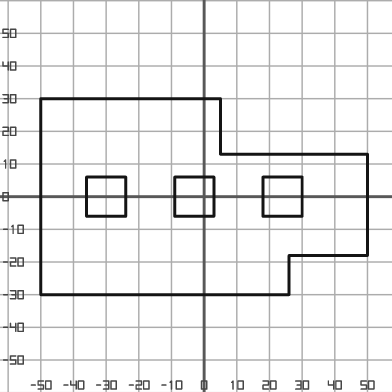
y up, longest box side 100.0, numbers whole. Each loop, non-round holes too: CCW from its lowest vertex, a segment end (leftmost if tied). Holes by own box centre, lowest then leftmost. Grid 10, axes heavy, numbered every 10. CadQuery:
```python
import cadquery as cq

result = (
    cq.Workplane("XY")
    .moveTo(-50.0, -30.0)
    .lineTo(26.0, -30.0)
    .lineTo(26.0, -18.0)
    .lineTo(50.0, -18.0)
    .lineTo(50.0, 13.0)
    .lineTo(5.0, 13.0)
    .lineTo(5.0, 30.0)
    .lineTo(-50.0, 30.0)
    .close()
    .moveTo(-36.0, -6.0)
    .lineTo(-24.0, -6.0)
    .lineTo(-24.0, 6.0)
    .lineTo(-36.0, 6.0)
    .close()
    .moveTo(-9.0, -6.0)
    .lineTo(3.0, -6.0)
    .lineTo(3.0, 6.0)
    .lineTo(-9.0, 6.0)
    .close()
    .moveTo(18.0, -6.0)
    .lineTo(30.0, -6.0)
    .lineTo(30.0, 6.0)
    .lineTo(18.0, 6.0)
    .close()
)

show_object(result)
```